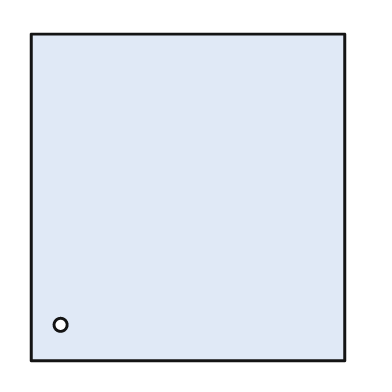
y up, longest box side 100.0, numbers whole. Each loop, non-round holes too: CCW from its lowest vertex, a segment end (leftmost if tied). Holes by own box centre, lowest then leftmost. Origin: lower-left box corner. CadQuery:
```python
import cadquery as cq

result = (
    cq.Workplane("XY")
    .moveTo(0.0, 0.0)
    .lineTo(96.0, 0.0)
    .lineTo(96.0, 100.0)
    .lineTo(0.0, 100.0)
    .close()
    .moveTo(9.0, 11.0)
    .circle(2.0)
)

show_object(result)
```